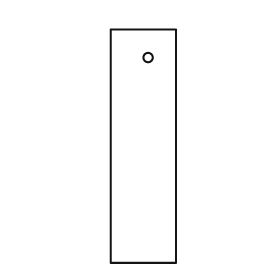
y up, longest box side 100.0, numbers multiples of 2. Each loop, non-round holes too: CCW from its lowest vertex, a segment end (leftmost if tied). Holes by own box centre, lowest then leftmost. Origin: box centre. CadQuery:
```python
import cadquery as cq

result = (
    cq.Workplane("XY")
    .moveTo(-14.0, -50.0)
    .lineTo(14.0, -50.0)
    .lineTo(14.0, 50.0)
    .lineTo(-14.0, 50.0)
    .close()
    .moveTo(2.0, 38.0)
    .circle(2.0)
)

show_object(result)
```